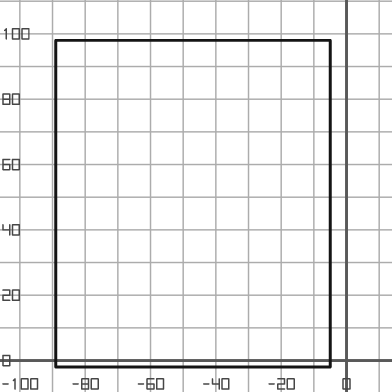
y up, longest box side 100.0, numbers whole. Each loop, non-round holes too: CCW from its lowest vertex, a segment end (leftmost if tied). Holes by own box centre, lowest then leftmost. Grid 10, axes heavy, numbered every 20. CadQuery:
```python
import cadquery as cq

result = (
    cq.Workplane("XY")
    .moveTo(-89.0, -2.0)
    .lineTo(-5.0, -2.0)
    .lineTo(-5.0, 98.0)
    .lineTo(-89.0, 98.0)
    .close()
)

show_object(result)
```